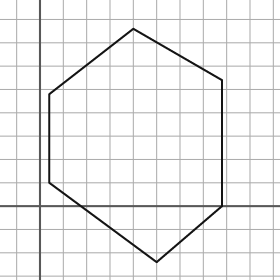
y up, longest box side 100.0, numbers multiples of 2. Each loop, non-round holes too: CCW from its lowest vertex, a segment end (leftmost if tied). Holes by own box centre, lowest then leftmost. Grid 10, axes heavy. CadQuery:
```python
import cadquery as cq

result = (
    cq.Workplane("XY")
    .moveTo(50.0, -24.0)
    .lineTo(78.0, 0.0)
    .lineTo(78.0, 54.0)
    .lineTo(40.0, 76.0)
    .lineTo(4.0, 48.0)
    .lineTo(4.0, 10.0)
    .close()
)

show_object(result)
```